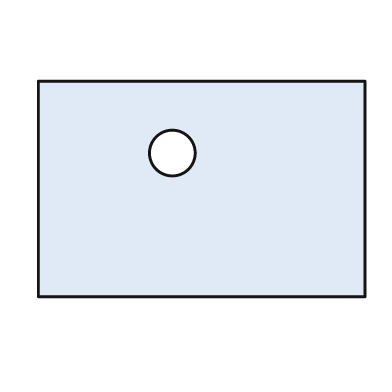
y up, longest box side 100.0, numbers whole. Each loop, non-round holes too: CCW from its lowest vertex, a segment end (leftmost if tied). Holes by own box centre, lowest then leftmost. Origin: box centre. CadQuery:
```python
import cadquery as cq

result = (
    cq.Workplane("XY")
    .moveTo(-50.0, -33.0)
    .lineTo(50.0, -33.0)
    .lineTo(50.0, 33.0)
    .lineTo(-50.0, 33.0)
    .close()
    .moveTo(-9.0, 11.0)
    .circle(7.0)
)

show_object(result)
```